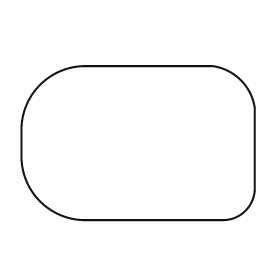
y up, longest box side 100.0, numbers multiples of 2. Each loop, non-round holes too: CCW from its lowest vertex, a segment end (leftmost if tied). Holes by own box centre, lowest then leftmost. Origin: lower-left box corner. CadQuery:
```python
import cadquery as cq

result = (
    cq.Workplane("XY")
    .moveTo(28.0, 0.0)
    .lineTo(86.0, 0.0)
    .threePointArc((96.0, 4.0), (100.0, 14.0))
    .lineTo(100.0, 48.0)
    .threePointArc((94.0, 60.0), (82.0, 66.0))
    .lineTo(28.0, 66.0)
    .threePointArc((8.0, 58.0), (0.0, 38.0))
    .lineTo(0.0, 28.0)
    .threePointArc((8.0, 8.0), (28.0, 0.0))
    .close()
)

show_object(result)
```